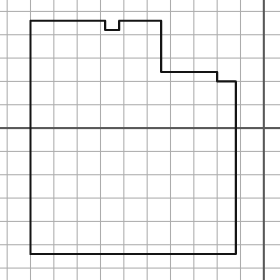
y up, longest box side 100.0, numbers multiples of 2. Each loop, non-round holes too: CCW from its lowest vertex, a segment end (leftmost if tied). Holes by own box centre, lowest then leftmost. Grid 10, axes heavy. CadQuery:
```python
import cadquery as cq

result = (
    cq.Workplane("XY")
    .moveTo(-100.0, -54.0)
    .lineTo(-12.0, -54.0)
    .lineTo(-12.0, 20.0)
    .lineTo(-20.0, 20.0)
    .lineTo(-20.0, 24.0)
    .lineTo(-44.0, 24.0)
    .lineTo(-44.0, 46.0)
    .lineTo(-62.0, 46.0)
    .lineTo(-62.0, 42.0)
    .lineTo(-68.0, 42.0)
    .lineTo(-68.0, 46.0)
    .lineTo(-100.0, 46.0)
    .close()
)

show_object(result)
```